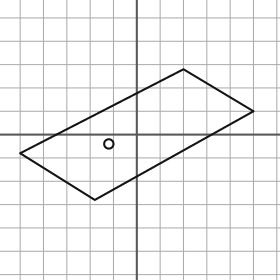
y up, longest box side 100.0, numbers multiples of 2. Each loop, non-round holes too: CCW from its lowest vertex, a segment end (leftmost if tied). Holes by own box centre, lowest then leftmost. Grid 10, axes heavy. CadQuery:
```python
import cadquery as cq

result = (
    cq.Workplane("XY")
    .moveTo(-18.0, -28.0)
    .lineTo(50.0, 10.0)
    .lineTo(20.0, 28.0)
    .lineTo(-50.0, -8.0)
    .close()
    .moveTo(-12.0, -4.0)
    .circle(2.0)
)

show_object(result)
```